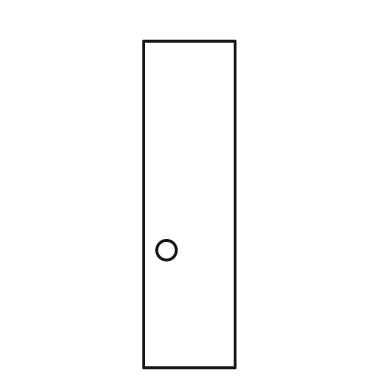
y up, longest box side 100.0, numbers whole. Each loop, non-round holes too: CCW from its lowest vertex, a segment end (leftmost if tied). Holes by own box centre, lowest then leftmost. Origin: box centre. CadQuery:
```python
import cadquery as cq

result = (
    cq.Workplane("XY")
    .moveTo(-14.0, -50.0)
    .lineTo(14.0, -50.0)
    .lineTo(14.0, 50.0)
    .lineTo(-14.0, 50.0)
    .close()
    .moveTo(-7.0, -14.0)
    .circle(3.0)
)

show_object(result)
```